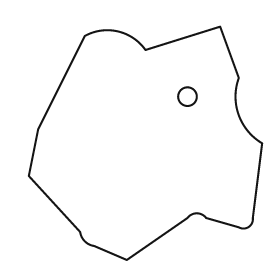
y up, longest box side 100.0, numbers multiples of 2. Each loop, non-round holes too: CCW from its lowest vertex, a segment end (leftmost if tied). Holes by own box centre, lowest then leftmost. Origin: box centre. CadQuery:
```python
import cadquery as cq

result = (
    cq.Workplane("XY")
    .moveTo(-8.0, -50.0)
    .lineTo(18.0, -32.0)
    .threePointArc((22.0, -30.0), (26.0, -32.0))
    .lineTo(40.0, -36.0)
    .threePointArc((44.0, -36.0), (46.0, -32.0))
    .lineTo(50.0, 0.0)
    .threePointArc((40.0, 12.0), (40.0, 28.0))
    .lineTo(32.0, 50.0)
    .lineTo(0.0, 40.0)
    .threePointArc((-12.0, 48.0), (-26.0, 46.0))
    .lineTo(-46.0, 6.0)
    .lineTo(-50.0, -14.0)
    .lineTo(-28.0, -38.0)
    .threePointArc((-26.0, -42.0), (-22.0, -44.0))
    .close()
    .moveTo(18.0, 20.0)
    .circle(4.0)
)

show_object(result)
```